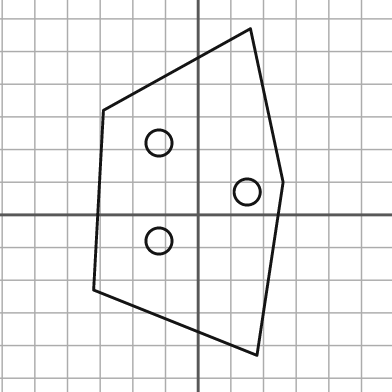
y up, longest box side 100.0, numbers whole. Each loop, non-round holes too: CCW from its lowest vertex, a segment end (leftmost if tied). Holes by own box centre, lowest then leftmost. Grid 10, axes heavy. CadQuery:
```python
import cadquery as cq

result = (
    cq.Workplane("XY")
    .moveTo(18.0, -43.0)
    .lineTo(26.0, 10.0)
    .lineTo(16.0, 57.0)
    .lineTo(-29.0, 32.0)
    .lineTo(-32.0, -23.0)
    .close()
    .moveTo(-12.0, -8.0)
    .circle(4.0)
    .moveTo(15.0, 7.0)
    .circle(4.0)
    .moveTo(-12.0, 22.0)
    .circle(4.0)
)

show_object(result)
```